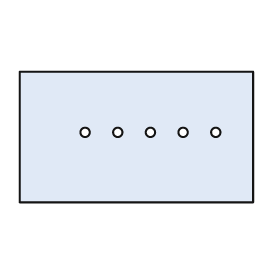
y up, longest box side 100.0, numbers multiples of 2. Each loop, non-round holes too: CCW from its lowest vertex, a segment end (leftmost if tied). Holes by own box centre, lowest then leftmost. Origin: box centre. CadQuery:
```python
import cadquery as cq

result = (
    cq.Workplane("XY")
    .moveTo(-50.0, -28.0)
    .lineTo(50.0, -28.0)
    .lineTo(50.0, 28.0)
    .lineTo(-50.0, 28.0)
    .close()
    .moveTo(-22.0, 2.0)
    .circle(2.0)
    .moveTo(-8.0, 2.0)
    .circle(2.0)
    .moveTo(6.0, 2.0)
    .circle(2.0)
    .moveTo(20.0, 2.0)
    .circle(2.0)
    .moveTo(34.0, 2.0)
    .circle(2.0)
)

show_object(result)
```